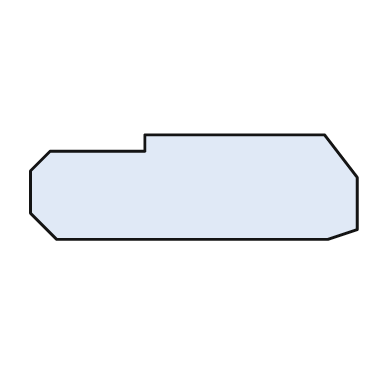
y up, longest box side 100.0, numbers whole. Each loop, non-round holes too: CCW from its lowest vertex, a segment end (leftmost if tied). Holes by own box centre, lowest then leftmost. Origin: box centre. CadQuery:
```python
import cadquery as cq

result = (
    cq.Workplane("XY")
    .moveTo(-42.0, -16.0)
    .lineTo(41.0, -16.0)
    .lineTo(50.0, -13.0)
    .lineTo(50.0, 3.0)
    .lineTo(40.0, 16.0)
    .lineTo(-15.0, 16.0)
    .lineTo(-15.0, 11.0)
    .lineTo(-44.0, 11.0)
    .lineTo(-50.0, 5.0)
    .lineTo(-50.0, -8.0)
    .close()
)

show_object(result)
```